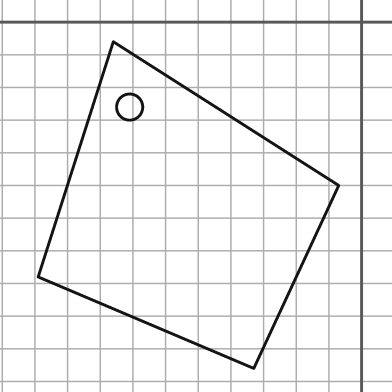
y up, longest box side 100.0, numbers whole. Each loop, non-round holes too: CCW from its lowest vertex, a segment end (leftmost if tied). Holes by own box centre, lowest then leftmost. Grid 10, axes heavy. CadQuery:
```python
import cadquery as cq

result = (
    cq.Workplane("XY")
    .moveTo(-33.0, -106.0)
    .lineTo(-7.0, -50.0)
    .lineTo(-76.0, -6.0)
    .lineTo(-99.0, -78.0)
    .close()
    .moveTo(-71.0, -26.0)
    .circle(4.0)
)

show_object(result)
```